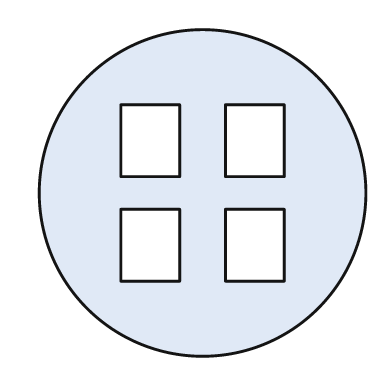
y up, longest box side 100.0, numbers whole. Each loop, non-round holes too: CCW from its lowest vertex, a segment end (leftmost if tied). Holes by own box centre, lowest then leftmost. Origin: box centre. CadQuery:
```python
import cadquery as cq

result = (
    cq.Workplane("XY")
    .moveTo(0.0, 0.0)
    .circle(50.0)
    .moveTo(-25.0, -27.0)
    .lineTo(-7.0, -27.0)
    .lineTo(-7.0, -5.0)
    .lineTo(-25.0, -5.0)
    .close()
    .moveTo(7.0, -27.0)
    .lineTo(25.0, -27.0)
    .lineTo(25.0, -5.0)
    .lineTo(7.0, -5.0)
    .close()
    .moveTo(-25.0, 5.0)
    .lineTo(-7.0, 5.0)
    .lineTo(-7.0, 27.0)
    .lineTo(-25.0, 27.0)
    .close()
    .moveTo(7.0, 5.0)
    .lineTo(25.0, 5.0)
    .lineTo(25.0, 27.0)
    .lineTo(7.0, 27.0)
    .close()
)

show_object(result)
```